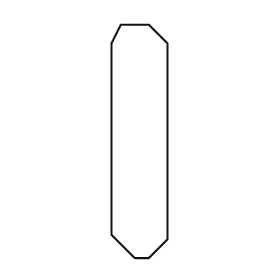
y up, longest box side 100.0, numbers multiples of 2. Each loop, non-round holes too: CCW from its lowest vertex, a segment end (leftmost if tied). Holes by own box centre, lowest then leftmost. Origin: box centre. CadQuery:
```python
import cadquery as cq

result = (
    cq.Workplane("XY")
    .moveTo(-2.0, -50.0)
    .lineTo(4.0, -50.0)
    .lineTo(12.0, -42.0)
    .lineTo(12.0, 42.0)
    .lineTo(4.0, 50.0)
    .lineTo(-8.0, 50.0)
    .lineTo(-12.0, 42.0)
    .lineTo(-12.0, -40.0)
    .close()
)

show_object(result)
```